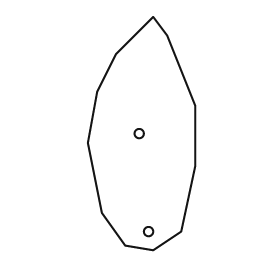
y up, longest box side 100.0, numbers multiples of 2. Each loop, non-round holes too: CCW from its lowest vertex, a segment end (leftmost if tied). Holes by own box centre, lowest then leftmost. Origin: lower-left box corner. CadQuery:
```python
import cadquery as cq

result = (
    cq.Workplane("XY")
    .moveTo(28.0, 0.0)
    .lineTo(40.0, 8.0)
    .lineTo(46.0, 36.0)
    .lineTo(46.0, 62.0)
    .lineTo(34.0, 92.0)
    .lineTo(28.0, 100.0)
    .lineTo(12.0, 84.0)
    .lineTo(4.0, 68.0)
    .lineTo(0.0, 46.0)
    .lineTo(6.0, 16.0)
    .lineTo(16.0, 2.0)
    .close()
    .moveTo(26.0, 8.0)
    .circle(2.0)
    .moveTo(22.0, 50.0)
    .circle(2.0)
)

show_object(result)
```